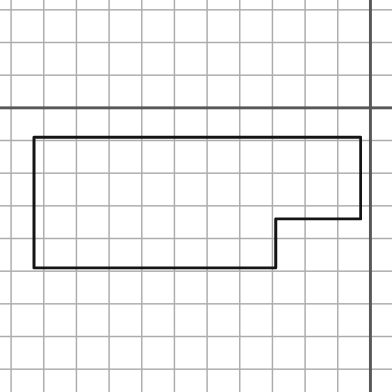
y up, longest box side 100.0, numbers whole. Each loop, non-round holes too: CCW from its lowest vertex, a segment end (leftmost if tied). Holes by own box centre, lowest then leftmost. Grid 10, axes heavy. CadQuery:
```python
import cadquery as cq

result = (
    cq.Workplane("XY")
    .moveTo(-103.0, -49.0)
    .lineTo(-29.0, -49.0)
    .lineTo(-29.0, -34.0)
    .lineTo(-3.0, -34.0)
    .lineTo(-3.0, -9.0)
    .lineTo(-103.0, -9.0)
    .close()
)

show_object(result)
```